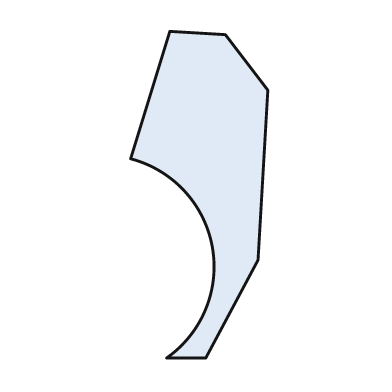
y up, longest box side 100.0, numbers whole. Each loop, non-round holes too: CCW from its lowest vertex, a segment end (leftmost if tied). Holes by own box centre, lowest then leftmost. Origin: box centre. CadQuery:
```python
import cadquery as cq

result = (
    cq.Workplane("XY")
    .moveTo(-10.0, -50.0)
    .lineTo(2.0, -50.0)
    .lineTo(18.0, -20.0)
    .lineTo(21.0, 32.0)
    .lineTo(8.0, 49.0)
    .lineTo(-9.0, 50.0)
    .lineTo(-21.0, 11.0)
    .threePointArc((4.0, -16.0), (-10.0, -50.0))
    .close()
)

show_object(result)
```